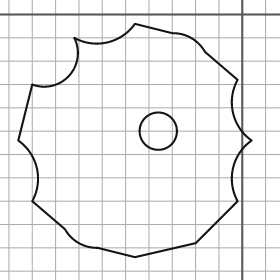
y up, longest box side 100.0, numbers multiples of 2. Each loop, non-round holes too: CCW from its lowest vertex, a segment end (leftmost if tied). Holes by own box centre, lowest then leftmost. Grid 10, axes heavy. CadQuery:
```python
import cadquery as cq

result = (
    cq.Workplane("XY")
    .moveTo(-46.0, -104.0)
    .lineTo(-20.0, -98.0)
    .lineTo(-2.0, -80.0)
    .threePointArc((-4.0, -66.0), (4.0, -54.0))
    .threePointArc((-4.0, -42.0), (-2.0, -28.0))
    .lineTo(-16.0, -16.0)
    .threePointArc((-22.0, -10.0), (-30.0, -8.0))
    .lineTo(-46.0, -4.0)
    .threePointArc((-58.0, -12.0), (-72.0, -10.0))
    .threePointArc((-74.0, -26.0), (-90.0, -30.0))
    .lineTo(-96.0, -54.0)
    .threePointArc((-88.0, -66.0), (-90.0, -80.0))
    .lineTo(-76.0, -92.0)
    .threePointArc((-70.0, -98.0), (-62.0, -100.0))
    .close()
    .moveTo(-36.0, -50.0)
    .circle(8.0)
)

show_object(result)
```